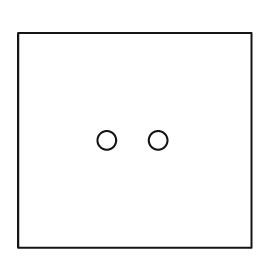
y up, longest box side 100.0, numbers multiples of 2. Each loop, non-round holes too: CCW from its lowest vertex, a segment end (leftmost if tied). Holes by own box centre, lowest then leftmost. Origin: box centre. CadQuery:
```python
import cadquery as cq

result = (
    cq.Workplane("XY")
    .moveTo(-50.0, -46.0)
    .lineTo(50.0, -46.0)
    .lineTo(50.0, 46.0)
    .lineTo(-50.0, 46.0)
    .close()
    .moveTo(-12.0, 0.0)
    .circle(4.0)
    .moveTo(10.0, 0.0)
    .circle(4.0)
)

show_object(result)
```